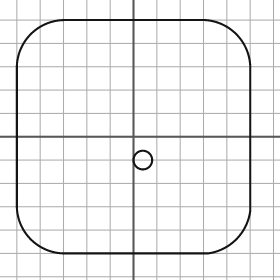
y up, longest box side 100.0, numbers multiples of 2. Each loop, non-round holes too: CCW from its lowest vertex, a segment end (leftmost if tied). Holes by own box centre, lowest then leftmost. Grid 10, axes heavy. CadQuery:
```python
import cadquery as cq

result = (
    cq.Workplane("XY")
    .moveTo(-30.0, -50.0)
    .lineTo(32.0, -50.0)
    .threePointArc((44.0, -44.0), (50.0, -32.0))
    .lineTo(50.0, 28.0)
    .threePointArc((44.0, 44.0), (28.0, 50.0))
    .lineTo(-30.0, 50.0)
    .threePointArc((-44.0, 44.0), (-50.0, 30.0))
    .lineTo(-50.0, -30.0)
    .threePointArc((-44.0, -44.0), (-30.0, -50.0))
    .close()
    .moveTo(4.0, -10.0)
    .circle(4.0)
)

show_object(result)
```